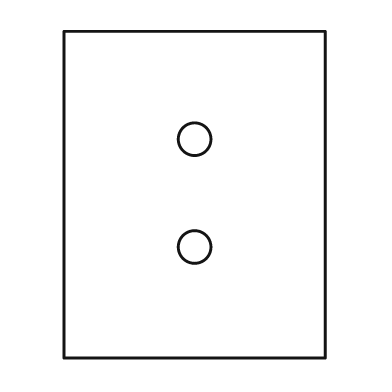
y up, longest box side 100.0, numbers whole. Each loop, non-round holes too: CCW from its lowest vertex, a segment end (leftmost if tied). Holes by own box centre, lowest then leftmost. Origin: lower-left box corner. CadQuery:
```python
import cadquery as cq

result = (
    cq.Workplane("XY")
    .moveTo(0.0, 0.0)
    .lineTo(80.0, 0.0)
    .lineTo(80.0, 100.0)
    .lineTo(0.0, 100.0)
    .close()
    .moveTo(40.0, 34.0)
    .circle(5.0)
    .moveTo(40.0, 67.0)
    .circle(5.0)
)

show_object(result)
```